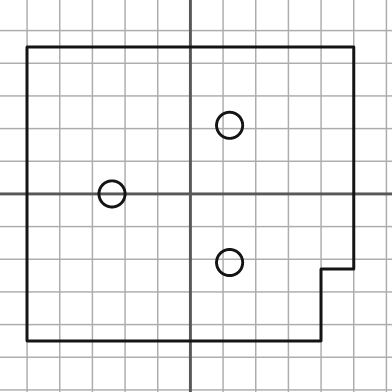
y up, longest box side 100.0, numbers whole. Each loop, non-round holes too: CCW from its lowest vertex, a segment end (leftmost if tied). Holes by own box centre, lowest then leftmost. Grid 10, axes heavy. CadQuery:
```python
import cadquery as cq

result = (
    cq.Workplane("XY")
    .moveTo(-50.0, -45.0)
    .lineTo(40.0, -45.0)
    .lineTo(40.0, -23.0)
    .lineTo(50.0, -23.0)
    .lineTo(50.0, 45.0)
    .lineTo(-50.0, 45.0)
    .close()
    .moveTo(12.0, -21.0)
    .circle(4.0)
    .moveTo(-24.0, 0.0)
    .circle(4.0)
    .moveTo(12.0, 21.0)
    .circle(4.0)
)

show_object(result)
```